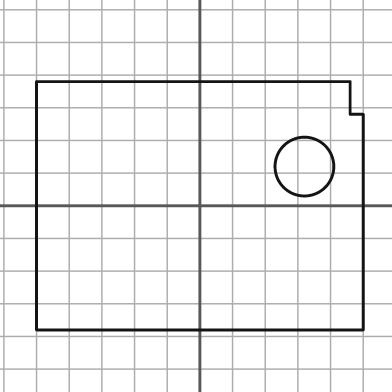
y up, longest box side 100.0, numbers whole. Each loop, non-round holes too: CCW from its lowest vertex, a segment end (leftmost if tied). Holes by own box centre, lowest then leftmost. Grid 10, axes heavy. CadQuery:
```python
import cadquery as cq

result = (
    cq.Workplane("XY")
    .moveTo(-50.0, -38.0)
    .lineTo(50.0, -38.0)
    .lineTo(50.0, 28.0)
    .lineTo(46.0, 28.0)
    .lineTo(46.0, 38.0)
    .lineTo(-50.0, 38.0)
    .close()
    .moveTo(32.0, 12.0)
    .circle(9.0)
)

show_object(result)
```